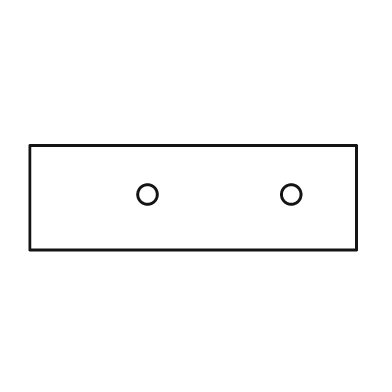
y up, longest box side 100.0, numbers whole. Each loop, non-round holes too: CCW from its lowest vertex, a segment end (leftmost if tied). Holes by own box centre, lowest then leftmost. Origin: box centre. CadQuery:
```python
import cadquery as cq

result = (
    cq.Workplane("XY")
    .moveTo(-50.0, -16.0)
    .lineTo(50.0, -16.0)
    .lineTo(50.0, 16.0)
    .lineTo(-50.0, 16.0)
    .close()
    .moveTo(-14.0, 1.0)
    .circle(3.0)
    .moveTo(30.0, 1.0)
    .circle(3.0)
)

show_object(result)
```